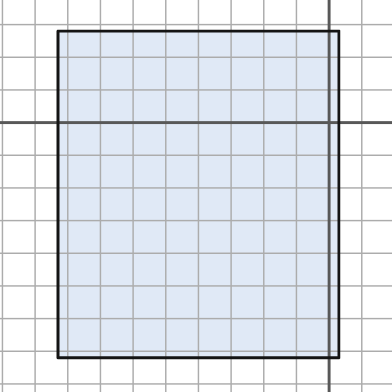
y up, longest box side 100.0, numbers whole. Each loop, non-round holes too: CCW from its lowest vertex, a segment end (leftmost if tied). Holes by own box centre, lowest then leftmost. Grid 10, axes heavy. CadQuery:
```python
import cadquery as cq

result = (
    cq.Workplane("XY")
    .moveTo(-83.0, -72.0)
    .lineTo(3.0, -72.0)
    .lineTo(3.0, 28.0)
    .lineTo(-83.0, 28.0)
    .close()
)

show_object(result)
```